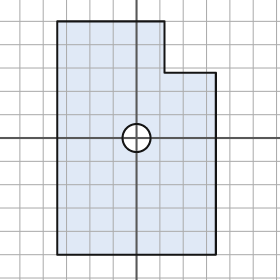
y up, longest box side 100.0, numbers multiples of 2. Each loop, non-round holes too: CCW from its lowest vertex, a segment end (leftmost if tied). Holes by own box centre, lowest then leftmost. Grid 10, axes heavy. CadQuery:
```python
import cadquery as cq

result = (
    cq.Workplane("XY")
    .moveTo(-34.0, -50.0)
    .lineTo(34.0, -50.0)
    .lineTo(34.0, 28.0)
    .lineTo(12.0, 28.0)
    .lineTo(12.0, 50.0)
    .lineTo(-34.0, 50.0)
    .close()
    .moveTo(0.0, 0.0)
    .circle(6.0)
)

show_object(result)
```